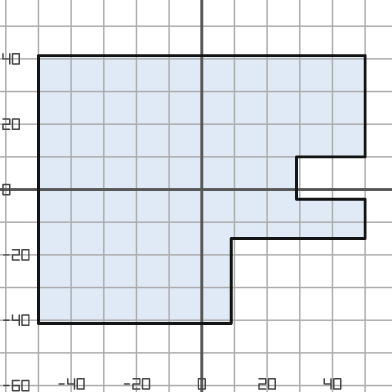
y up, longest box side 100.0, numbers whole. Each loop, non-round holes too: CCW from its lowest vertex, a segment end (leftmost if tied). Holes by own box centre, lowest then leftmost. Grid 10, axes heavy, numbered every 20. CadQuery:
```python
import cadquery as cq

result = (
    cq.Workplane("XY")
    .moveTo(-50.0, -41.0)
    .lineTo(9.0, -41.0)
    .lineTo(9.0, -15.0)
    .lineTo(50.0, -15.0)
    .lineTo(50.0, -3.0)
    .lineTo(29.0, -3.0)
    .lineTo(29.0, 10.0)
    .lineTo(50.0, 10.0)
    .lineTo(50.0, 41.0)
    .lineTo(-50.0, 41.0)
    .close()
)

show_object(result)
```